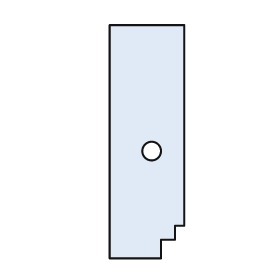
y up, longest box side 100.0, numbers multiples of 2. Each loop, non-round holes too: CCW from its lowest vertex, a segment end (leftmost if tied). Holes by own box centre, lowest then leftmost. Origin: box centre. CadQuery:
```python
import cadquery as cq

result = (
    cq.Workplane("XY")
    .moveTo(-16.0, -50.0)
    .lineTo(6.0, -50.0)
    .lineTo(6.0, -42.0)
    .lineTo(12.0, -42.0)
    .lineTo(12.0, -36.0)
    .lineTo(16.0, -36.0)
    .lineTo(16.0, 50.0)
    .lineTo(-16.0, 50.0)
    .close()
    .moveTo(2.0, -4.0)
    .circle(4.0)
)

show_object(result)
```